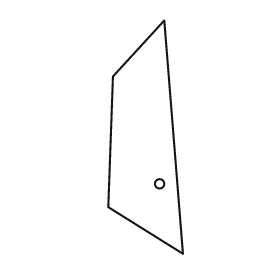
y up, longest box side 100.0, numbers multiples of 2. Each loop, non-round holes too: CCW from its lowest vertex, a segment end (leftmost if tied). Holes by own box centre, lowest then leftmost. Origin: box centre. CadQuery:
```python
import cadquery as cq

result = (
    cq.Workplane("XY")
    .moveTo(16.0, -50.0)
    .lineTo(8.0, 50.0)
    .lineTo(-14.0, 26.0)
    .lineTo(-16.0, -30.0)
    .close()
    .moveTo(6.0, -20.0)
    .circle(2.0)
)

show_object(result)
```